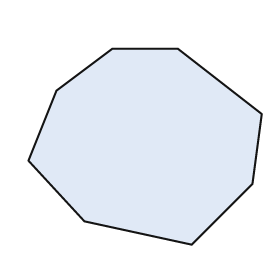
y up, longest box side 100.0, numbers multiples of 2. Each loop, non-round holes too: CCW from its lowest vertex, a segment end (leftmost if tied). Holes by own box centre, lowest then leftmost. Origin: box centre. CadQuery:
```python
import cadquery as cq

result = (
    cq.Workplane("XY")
    .moveTo(20.0, -42.0)
    .lineTo(46.0, -16.0)
    .lineTo(50.0, 14.0)
    .lineTo(14.0, 42.0)
    .lineTo(-14.0, 42.0)
    .lineTo(-38.0, 24.0)
    .lineTo(-50.0, -6.0)
    .lineTo(-26.0, -32.0)
    .close()
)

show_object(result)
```